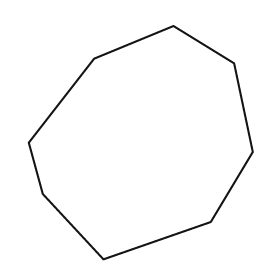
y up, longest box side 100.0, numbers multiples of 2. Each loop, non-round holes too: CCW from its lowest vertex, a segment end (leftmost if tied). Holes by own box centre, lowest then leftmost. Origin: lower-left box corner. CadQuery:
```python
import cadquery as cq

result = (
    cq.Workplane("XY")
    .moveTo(32.0, 0.0)
    .lineTo(78.0, 16.0)
    .lineTo(96.0, 46.0)
    .lineTo(88.0, 84.0)
    .lineTo(62.0, 100.0)
    .lineTo(28.0, 86.0)
    .lineTo(0.0, 50.0)
    .lineTo(6.0, 28.0)
    .close()
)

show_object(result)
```